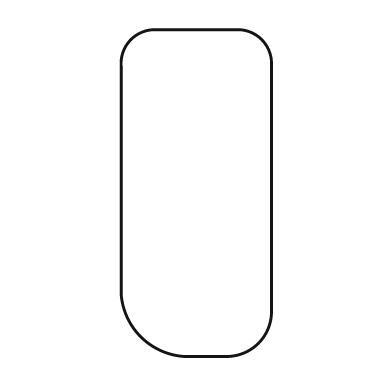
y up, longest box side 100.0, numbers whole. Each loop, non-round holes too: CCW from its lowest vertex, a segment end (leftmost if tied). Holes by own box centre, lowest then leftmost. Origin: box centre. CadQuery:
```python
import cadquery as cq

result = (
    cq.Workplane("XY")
    .moveTo(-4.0, -50.0)
    .lineTo(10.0, -50.0)
    .threePointArc((19.0, -46.0), (23.0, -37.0))
    .lineTo(23.0, 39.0)
    .threePointArc((20.0, 47.0), (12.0, 50.0))
    .lineTo(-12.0, 50.0)
    .threePointArc((-20.0, 47.0), (-23.0, 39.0))
    .lineTo(-23.0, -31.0)
    .threePointArc((-17.0, -44.0), (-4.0, -50.0))
    .close()
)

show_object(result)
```